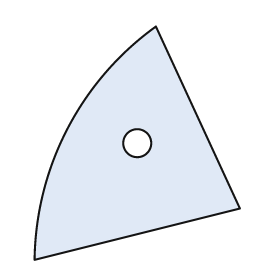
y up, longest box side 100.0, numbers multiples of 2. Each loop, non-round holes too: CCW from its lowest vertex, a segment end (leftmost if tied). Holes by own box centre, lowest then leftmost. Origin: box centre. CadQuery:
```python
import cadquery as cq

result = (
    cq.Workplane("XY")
    .moveTo(-44.0, -50.0)
    .lineTo(44.0, -28.0)
    .lineTo(8.0, 50.0)
    .threePointArc((-30.0, 6.0), (-44.0, -50.0))
    .close()
    .moveTo(0.0, 0.0)
    .circle(6.0)
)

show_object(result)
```